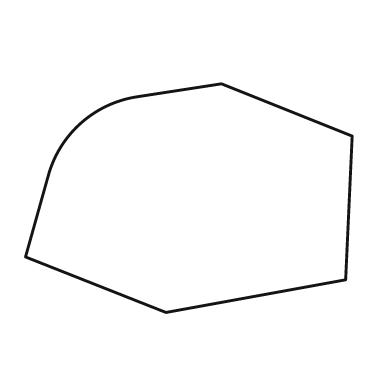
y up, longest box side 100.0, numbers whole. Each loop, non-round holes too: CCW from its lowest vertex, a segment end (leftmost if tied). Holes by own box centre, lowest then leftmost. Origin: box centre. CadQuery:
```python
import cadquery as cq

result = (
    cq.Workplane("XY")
    .moveTo(-7.0, -35.0)
    .lineTo(48.0, -25.0)
    .lineTo(50.0, 19.0)
    .lineTo(10.0, 35.0)
    .lineTo(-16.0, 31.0)
    .threePointArc((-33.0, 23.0), (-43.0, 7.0))
    .lineTo(-50.0, -18.0)
    .close()
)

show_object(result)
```